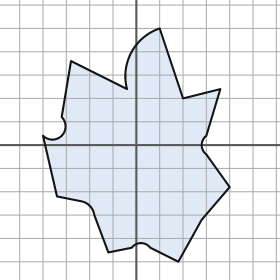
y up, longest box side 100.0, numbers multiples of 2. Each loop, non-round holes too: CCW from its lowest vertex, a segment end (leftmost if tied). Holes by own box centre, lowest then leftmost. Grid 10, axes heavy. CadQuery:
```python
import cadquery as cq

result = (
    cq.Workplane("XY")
    .moveTo(18.0, -50.0)
    .lineTo(28.0, -32.0)
    .lineTo(40.0, -18.0)
    .lineTo(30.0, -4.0)
    .threePointArc((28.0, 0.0), (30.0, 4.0))
    .lineTo(36.0, 24.0)
    .lineTo(20.0, 20.0)
    .lineTo(10.0, 50.0)
    .threePointArc((-2.0, 40.0), (-4.0, 24.0))
    .lineTo(-28.0, 36.0)
    .lineTo(-32.0, 12.0)
    .threePointArc((-32.0, 4.0), (-40.0, 4.0))
    .lineTo(-34.0, -22.0)
    .lineTo(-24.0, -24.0)
    .threePointArc((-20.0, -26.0), (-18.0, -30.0))
    .lineTo(-12.0, -46.0)
    .lineTo(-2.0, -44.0)
    .threePointArc((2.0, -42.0), (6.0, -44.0))
    .close()
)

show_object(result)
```